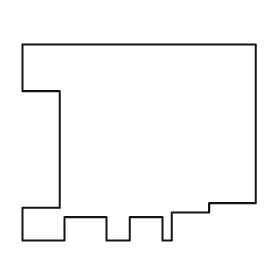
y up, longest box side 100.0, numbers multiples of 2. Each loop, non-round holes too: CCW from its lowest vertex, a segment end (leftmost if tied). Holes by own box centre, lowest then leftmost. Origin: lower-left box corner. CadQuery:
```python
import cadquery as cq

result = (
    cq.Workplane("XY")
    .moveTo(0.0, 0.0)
    .lineTo(18.0, 0.0)
    .lineTo(18.0, 10.0)
    .lineTo(36.0, 10.0)
    .lineTo(36.0, 0.0)
    .lineTo(46.0, 0.0)
    .lineTo(46.0, 10.0)
    .lineTo(60.0, 10.0)
    .lineTo(60.0, 0.0)
    .lineTo(64.0, 0.0)
    .lineTo(64.0, 12.0)
    .lineTo(80.0, 12.0)
    .lineTo(80.0, 16.0)
    .lineTo(100.0, 16.0)
    .lineTo(100.0, 84.0)
    .lineTo(0.0, 84.0)
    .lineTo(0.0, 64.0)
    .lineTo(16.0, 64.0)
    .lineTo(16.0, 14.0)
    .lineTo(0.0, 14.0)
    .close()
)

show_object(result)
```